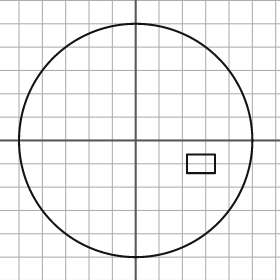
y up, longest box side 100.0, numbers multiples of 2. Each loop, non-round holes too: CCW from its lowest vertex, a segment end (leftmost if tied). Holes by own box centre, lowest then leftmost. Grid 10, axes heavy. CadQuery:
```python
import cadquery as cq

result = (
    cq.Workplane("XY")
    .moveTo(0.0, 0.0)
    .circle(50.0)
    .moveTo(22.0, -14.0)
    .lineTo(34.0, -14.0)
    .lineTo(34.0, -6.0)
    .lineTo(22.0, -6.0)
    .close()
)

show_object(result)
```